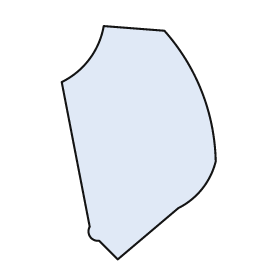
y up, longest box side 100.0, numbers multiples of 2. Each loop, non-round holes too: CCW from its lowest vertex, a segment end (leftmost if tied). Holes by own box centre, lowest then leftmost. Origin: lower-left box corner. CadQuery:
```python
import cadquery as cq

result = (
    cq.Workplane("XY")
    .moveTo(24.0, 0.0)
    .lineTo(50.0, 22.0)
    .threePointArc((60.0, 30.0), (66.0, 42.0))
    .threePointArc((60.0, 72.0), (44.0, 98.0))
    .lineTo(18.0, 100.0)
    .threePointArc((12.0, 86.0), (0.0, 76.0))
    .lineTo(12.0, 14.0)
    .threePointArc((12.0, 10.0), (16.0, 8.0))
    .close()
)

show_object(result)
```